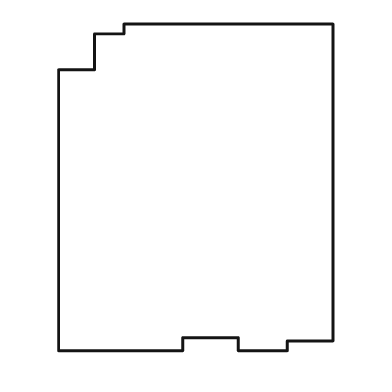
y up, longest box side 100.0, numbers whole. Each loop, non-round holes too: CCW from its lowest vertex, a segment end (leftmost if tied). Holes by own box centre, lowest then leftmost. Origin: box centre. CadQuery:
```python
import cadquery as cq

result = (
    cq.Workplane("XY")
    .moveTo(-42.0, -50.0)
    .lineTo(-4.0, -50.0)
    .lineTo(-4.0, -46.0)
    .lineTo(13.0, -46.0)
    .lineTo(13.0, -50.0)
    .lineTo(28.0, -50.0)
    .lineTo(28.0, -47.0)
    .lineTo(42.0, -47.0)
    .lineTo(42.0, 50.0)
    .lineTo(-22.0, 50.0)
    .lineTo(-22.0, 47.0)
    .lineTo(-31.0, 47.0)
    .lineTo(-31.0, 36.0)
    .lineTo(-42.0, 36.0)
    .close()
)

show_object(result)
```